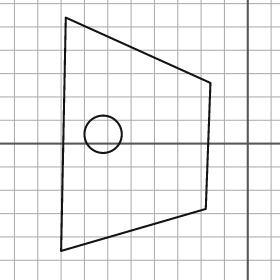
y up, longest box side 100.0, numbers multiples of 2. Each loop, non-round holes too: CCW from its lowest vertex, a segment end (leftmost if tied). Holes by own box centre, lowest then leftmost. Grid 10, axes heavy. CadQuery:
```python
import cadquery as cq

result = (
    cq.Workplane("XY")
    .moveTo(-80.0, -46.0)
    .lineTo(-18.0, -28.0)
    .lineTo(-16.0, 26.0)
    .lineTo(-78.0, 54.0)
    .close()
    .moveTo(-62.0, 4.0)
    .circle(8.0)
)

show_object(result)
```